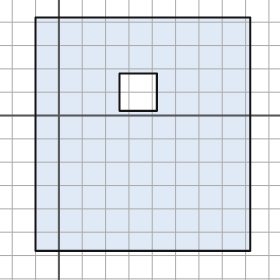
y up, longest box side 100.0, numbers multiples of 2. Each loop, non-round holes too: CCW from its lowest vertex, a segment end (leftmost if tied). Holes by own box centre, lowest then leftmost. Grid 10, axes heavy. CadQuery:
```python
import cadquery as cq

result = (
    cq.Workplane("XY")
    .moveTo(-10.0, -58.0)
    .lineTo(82.0, -58.0)
    .lineTo(82.0, 42.0)
    .lineTo(-10.0, 42.0)
    .close()
    .moveTo(26.0, 2.0)
    .lineTo(42.0, 2.0)
    .lineTo(42.0, 18.0)
    .lineTo(26.0, 18.0)
    .close()
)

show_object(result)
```